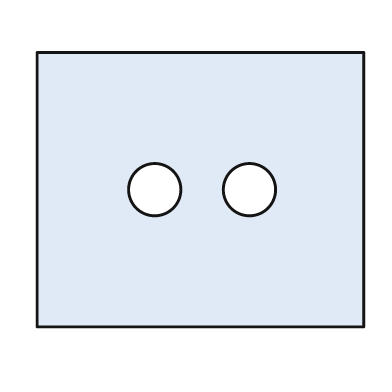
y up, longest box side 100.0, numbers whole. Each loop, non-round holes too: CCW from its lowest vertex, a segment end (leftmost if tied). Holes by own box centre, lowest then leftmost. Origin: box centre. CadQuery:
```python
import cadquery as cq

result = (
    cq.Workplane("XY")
    .moveTo(-50.0, -42.0)
    .lineTo(50.0, -42.0)
    .lineTo(50.0, 42.0)
    .lineTo(-50.0, 42.0)
    .close()
    .moveTo(-14.0, 0.0)
    .circle(8.0)
    .moveTo(15.0, 0.0)
    .circle(8.0)
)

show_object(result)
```